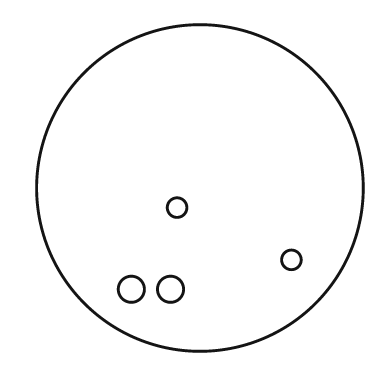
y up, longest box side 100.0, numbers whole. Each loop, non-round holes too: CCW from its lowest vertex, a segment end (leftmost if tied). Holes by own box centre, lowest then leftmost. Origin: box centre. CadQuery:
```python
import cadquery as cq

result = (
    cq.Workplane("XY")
    .moveTo(0.0, 0.0)
    .circle(50.0)
    .moveTo(-21.0, -31.0)
    .circle(4.0)
    .moveTo(-9.0, -31.0)
    .circle(4.0)
    .moveTo(28.0, -22.0)
    .circle(3.0)
    .moveTo(-7.0, -6.0)
    .circle(3.0)
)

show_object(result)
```